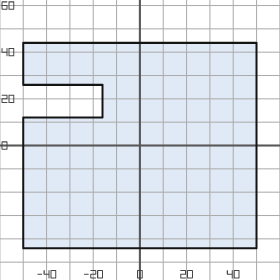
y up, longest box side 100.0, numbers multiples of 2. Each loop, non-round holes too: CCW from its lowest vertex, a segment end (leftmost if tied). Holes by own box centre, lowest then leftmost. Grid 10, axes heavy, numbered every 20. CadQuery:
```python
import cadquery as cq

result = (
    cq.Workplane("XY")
    .moveTo(-50.0, -44.0)
    .lineTo(50.0, -44.0)
    .lineTo(50.0, 44.0)
    .lineTo(-50.0, 44.0)
    .lineTo(-50.0, 26.0)
    .lineTo(-16.0, 26.0)
    .lineTo(-16.0, 12.0)
    .lineTo(-50.0, 12.0)
    .close()
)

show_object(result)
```